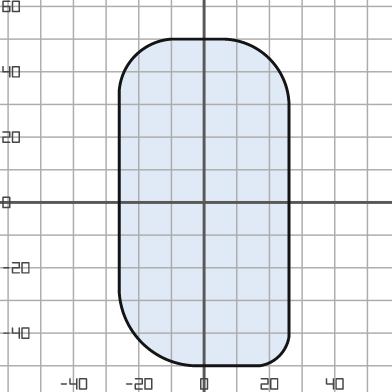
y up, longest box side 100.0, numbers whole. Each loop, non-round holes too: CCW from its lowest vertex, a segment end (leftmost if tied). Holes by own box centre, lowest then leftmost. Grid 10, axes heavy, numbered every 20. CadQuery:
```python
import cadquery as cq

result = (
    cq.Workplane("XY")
    .moveTo(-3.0, -50.0)
    .lineTo(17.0, -50.0)
    .threePointArc((23.0, -47.0), (26.0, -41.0))
    .lineTo(26.0, 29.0)
    .threePointArc((20.0, 44.0), (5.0, 50.0))
    .lineTo(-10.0, 50.0)
    .threePointArc((-21.0, 45.0), (-26.0, 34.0))
    .lineTo(-26.0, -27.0)
    .threePointArc((-19.0, -43.0), (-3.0, -50.0))
    .close()
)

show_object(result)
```